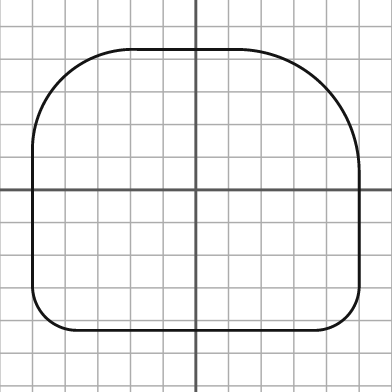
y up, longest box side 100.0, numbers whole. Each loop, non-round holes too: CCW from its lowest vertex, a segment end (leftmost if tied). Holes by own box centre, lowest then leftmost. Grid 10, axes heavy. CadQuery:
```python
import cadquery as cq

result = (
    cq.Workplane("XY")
    .moveTo(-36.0, -43.0)
    .lineTo(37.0, -43.0)
    .threePointArc((46.0, -39.0), (50.0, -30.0))
    .lineTo(50.0, 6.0)
    .threePointArc((39.0, 32.0), (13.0, 43.0))
    .lineTo(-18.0, 43.0)
    .threePointArc((-41.0, 34.0), (-50.0, 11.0))
    .lineTo(-50.0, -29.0)
    .threePointArc((-46.0, -39.0), (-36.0, -43.0))
    .close()
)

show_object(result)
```